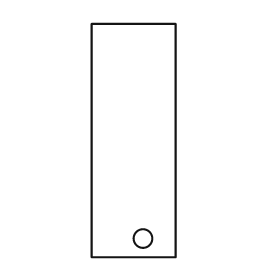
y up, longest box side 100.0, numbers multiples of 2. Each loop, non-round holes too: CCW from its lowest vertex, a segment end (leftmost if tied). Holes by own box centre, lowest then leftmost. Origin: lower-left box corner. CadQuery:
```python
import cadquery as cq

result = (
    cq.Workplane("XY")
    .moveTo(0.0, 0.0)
    .lineTo(36.0, 0.0)
    .lineTo(36.0, 100.0)
    .lineTo(0.0, 100.0)
    .close()
    .moveTo(22.0, 8.0)
    .circle(4.0)
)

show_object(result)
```